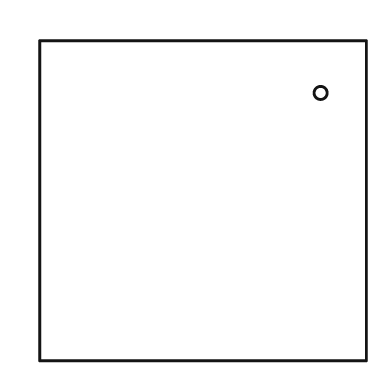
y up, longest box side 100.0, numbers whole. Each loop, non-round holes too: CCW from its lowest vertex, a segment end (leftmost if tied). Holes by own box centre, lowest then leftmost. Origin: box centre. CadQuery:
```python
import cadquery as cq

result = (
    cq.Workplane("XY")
    .moveTo(-50.0, -49.0)
    .lineTo(50.0, -49.0)
    .lineTo(50.0, 49.0)
    .lineTo(-50.0, 49.0)
    .close()
    .moveTo(36.0, 33.0)
    .circle(2.0)
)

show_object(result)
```